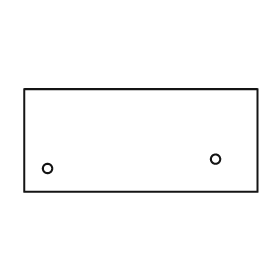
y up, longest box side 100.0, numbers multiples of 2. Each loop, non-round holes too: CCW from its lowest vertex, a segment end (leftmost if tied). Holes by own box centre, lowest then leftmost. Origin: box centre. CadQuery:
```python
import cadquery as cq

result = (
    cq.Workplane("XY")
    .moveTo(-50.0, -22.0)
    .lineTo(50.0, -22.0)
    .lineTo(50.0, 22.0)
    .lineTo(-50.0, 22.0)
    .close()
    .moveTo(-40.0, -12.0)
    .circle(2.0)
    .moveTo(32.0, -8.0)
    .circle(2.0)
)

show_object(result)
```